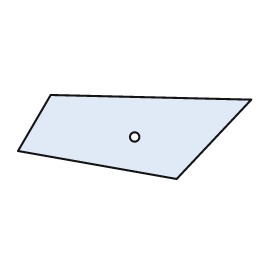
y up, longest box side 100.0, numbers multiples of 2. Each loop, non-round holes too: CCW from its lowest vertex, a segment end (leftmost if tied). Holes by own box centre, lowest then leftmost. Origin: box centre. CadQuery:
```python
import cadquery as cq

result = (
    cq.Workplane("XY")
    .moveTo(18.0, -18.0)
    .lineTo(50.0, 16.0)
    .lineTo(-36.0, 18.0)
    .lineTo(-50.0, -6.0)
    .close()
    .moveTo(0.0, 0.0)
    .circle(2.0)
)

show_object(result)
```